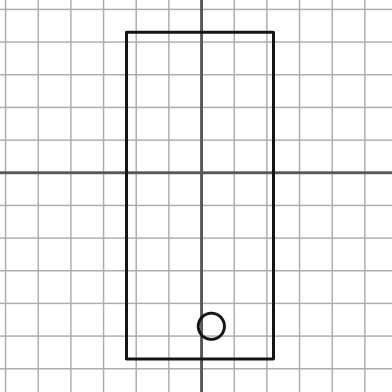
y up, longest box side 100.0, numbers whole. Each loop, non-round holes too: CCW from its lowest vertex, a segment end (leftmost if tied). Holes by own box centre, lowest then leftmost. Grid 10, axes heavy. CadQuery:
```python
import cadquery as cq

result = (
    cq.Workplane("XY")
    .moveTo(-23.0, -57.0)
    .lineTo(22.0, -57.0)
    .lineTo(22.0, 43.0)
    .lineTo(-23.0, 43.0)
    .close()
    .moveTo(3.0, -47.0)
    .circle(4.0)
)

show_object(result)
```